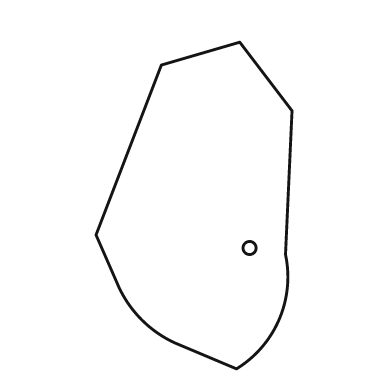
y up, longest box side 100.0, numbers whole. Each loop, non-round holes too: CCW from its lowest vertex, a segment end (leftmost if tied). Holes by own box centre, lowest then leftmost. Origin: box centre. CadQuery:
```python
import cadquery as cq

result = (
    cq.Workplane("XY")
    .moveTo(13.0, -50.0)
    .threePointArc((26.0, -35.0), (28.0, -15.0))
    .lineTo(30.0, 29.0)
    .lineTo(14.0, 50.0)
    .lineTo(-10.0, 43.0)
    .lineTo(-30.0, -9.0)
    .lineTo(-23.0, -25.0)
    .threePointArc((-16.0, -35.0), (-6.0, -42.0))
    .close()
    .moveTo(17.0, -13.0)
    .circle(2.0)
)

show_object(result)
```